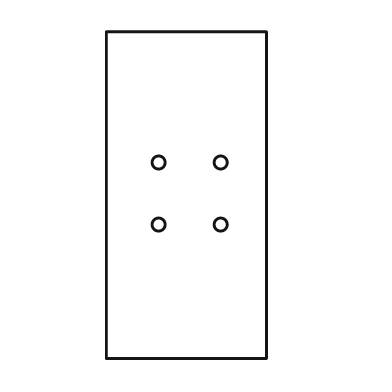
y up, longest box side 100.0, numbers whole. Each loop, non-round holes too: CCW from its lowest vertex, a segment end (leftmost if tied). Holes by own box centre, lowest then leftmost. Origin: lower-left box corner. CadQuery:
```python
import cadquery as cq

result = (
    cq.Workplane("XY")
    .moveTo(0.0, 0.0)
    .lineTo(49.0, 0.0)
    .lineTo(49.0, 100.0)
    .lineTo(0.0, 100.0)
    .close()
    .moveTo(16.0, 41.0)
    .circle(2.0)
    .moveTo(35.0, 41.0)
    .circle(2.0)
    .moveTo(16.0, 60.0)
    .circle(2.0)
    .moveTo(35.0, 60.0)
    .circle(2.0)
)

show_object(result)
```